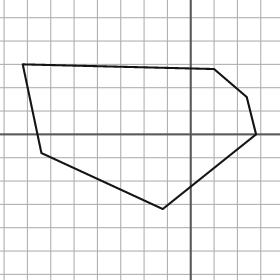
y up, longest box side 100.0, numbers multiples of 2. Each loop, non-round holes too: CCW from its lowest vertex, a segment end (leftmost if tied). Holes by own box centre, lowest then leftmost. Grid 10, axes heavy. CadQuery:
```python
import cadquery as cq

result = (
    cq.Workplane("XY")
    .moveTo(-12.0, -32.0)
    .lineTo(28.0, 0.0)
    .lineTo(24.0, 16.0)
    .lineTo(10.0, 28.0)
    .lineTo(-72.0, 30.0)
    .lineTo(-64.0, -8.0)
    .close()
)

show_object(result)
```